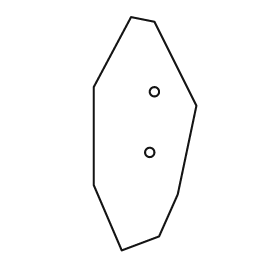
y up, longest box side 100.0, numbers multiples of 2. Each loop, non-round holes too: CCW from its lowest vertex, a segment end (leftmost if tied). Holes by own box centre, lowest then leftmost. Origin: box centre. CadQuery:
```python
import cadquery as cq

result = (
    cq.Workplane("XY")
    .moveTo(-10.0, -50.0)
    .lineTo(6.0, -44.0)
    .lineTo(14.0, -26.0)
    .lineTo(22.0, 12.0)
    .lineTo(4.0, 48.0)
    .lineTo(-6.0, 50.0)
    .lineTo(-22.0, 20.0)
    .lineTo(-22.0, -22.0)
    .close()
    .moveTo(2.0, -8.0)
    .circle(2.0)
    .moveTo(4.0, 18.0)
    .circle(2.0)
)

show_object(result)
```